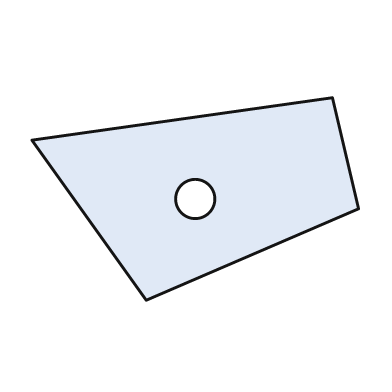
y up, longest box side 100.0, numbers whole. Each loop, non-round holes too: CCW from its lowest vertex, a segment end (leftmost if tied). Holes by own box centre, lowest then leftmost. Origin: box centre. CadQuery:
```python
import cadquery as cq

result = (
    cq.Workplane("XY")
    .moveTo(-15.0, -31.0)
    .lineTo(50.0, -3.0)
    .lineTo(42.0, 31.0)
    .lineTo(-50.0, 18.0)
    .close()
    .moveTo(0.0, 0.0)
    .circle(6.0)
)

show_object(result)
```